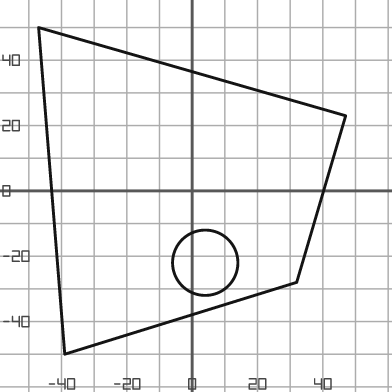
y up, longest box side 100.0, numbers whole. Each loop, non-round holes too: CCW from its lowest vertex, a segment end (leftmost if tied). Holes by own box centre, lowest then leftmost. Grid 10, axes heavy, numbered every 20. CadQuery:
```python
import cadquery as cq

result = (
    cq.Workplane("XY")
    .moveTo(-39.0, -50.0)
    .lineTo(32.0, -28.0)
    .lineTo(47.0, 23.0)
    .lineTo(-47.0, 50.0)
    .close()
    .moveTo(4.0, -22.0)
    .circle(10.0)
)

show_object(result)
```